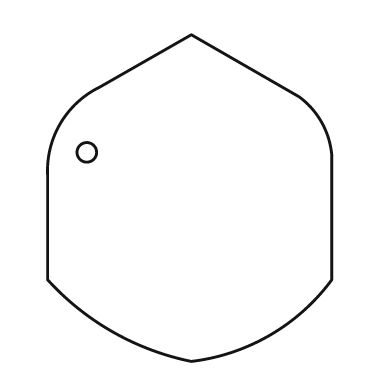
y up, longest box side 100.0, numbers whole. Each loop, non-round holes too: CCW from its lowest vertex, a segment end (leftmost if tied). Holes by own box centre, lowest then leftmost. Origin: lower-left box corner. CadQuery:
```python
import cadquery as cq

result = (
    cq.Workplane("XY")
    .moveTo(44.0, 0.0)
    .threePointArc((68.0, 8.0), (87.0, 25.0))
    .lineTo(87.0, 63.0)
    .threePointArc((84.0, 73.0), (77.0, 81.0))
    .lineTo(44.0, 100.0)
    .lineTo(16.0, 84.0)
    .threePointArc((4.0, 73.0), (0.0, 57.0))
    .lineTo(0.0, 25.0)
    .threePointArc((20.0, 9.0), (44.0, 0.0))
    .close()
    .moveTo(12.0, 64.0)
    .circle(3.0)
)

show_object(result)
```